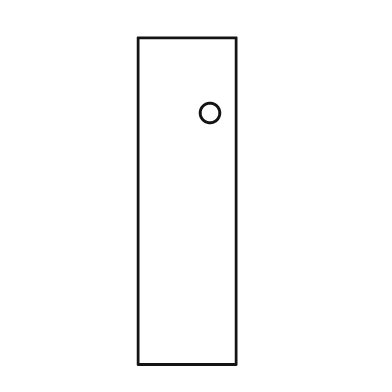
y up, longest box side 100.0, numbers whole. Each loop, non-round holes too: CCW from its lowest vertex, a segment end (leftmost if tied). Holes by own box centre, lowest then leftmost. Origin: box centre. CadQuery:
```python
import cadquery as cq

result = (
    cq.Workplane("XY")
    .moveTo(-15.0, -50.0)
    .lineTo(15.0, -50.0)
    .lineTo(15.0, 50.0)
    .lineTo(-15.0, 50.0)
    .close()
    .moveTo(7.0, 27.0)
    .circle(3.0)
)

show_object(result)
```